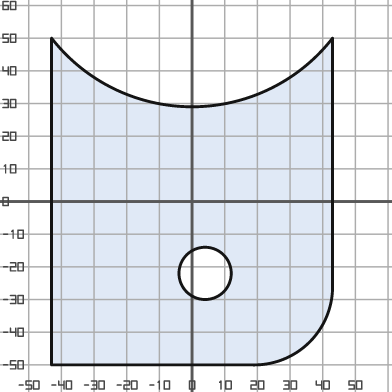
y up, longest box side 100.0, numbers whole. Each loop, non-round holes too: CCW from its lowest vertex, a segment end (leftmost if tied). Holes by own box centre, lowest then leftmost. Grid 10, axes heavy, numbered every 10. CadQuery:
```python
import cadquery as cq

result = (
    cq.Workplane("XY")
    .moveTo(-43.0, -50.0)
    .lineTo(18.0, -50.0)
    .threePointArc((36.0, -43.0), (43.0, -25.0))
    .lineTo(43.0, 50.0)
    .threePointArc((0.0, 29.0), (-43.0, 50.0))
    .close()
    .moveTo(4.0, -22.0)
    .circle(8.0)
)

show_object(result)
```